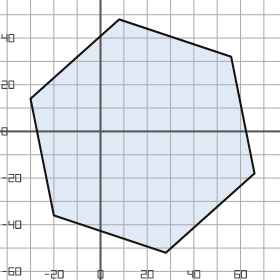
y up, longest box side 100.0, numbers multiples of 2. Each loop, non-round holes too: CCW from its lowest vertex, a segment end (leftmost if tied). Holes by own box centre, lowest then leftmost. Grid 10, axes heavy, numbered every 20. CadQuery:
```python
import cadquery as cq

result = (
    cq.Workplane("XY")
    .moveTo(28.0, -52.0)
    .lineTo(66.0, -18.0)
    .lineTo(56.0, 32.0)
    .lineTo(8.0, 48.0)
    .lineTo(-30.0, 14.0)
    .lineTo(-20.0, -36.0)
    .close()
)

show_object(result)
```